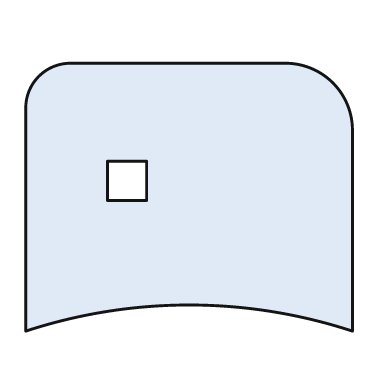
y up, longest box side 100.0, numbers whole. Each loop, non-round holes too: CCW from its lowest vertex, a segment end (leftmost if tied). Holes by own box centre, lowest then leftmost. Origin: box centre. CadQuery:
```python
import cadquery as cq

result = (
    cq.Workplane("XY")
    .moveTo(-50.0, -41.0)
    .threePointArc((0.0, -33.0), (50.0, -41.0))
    .lineTo(50.0, 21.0)
    .threePointArc((44.0, 35.0), (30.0, 41.0))
    .lineTo(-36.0, 41.0)
    .threePointArc((-46.0, 37.0), (-50.0, 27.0))
    .close()
    .moveTo(-25.0, -1.0)
    .lineTo(-13.0, -1.0)
    .lineTo(-13.0, 11.0)
    .lineTo(-25.0, 11.0)
    .close()
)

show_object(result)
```